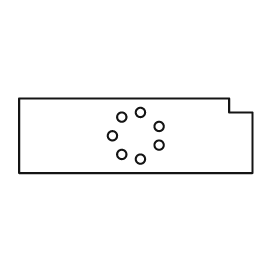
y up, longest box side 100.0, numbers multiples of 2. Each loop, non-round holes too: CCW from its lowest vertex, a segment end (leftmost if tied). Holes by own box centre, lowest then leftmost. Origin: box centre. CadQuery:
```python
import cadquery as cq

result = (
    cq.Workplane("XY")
    .moveTo(-50.0, -16.0)
    .lineTo(50.0, -16.0)
    .lineTo(50.0, 10.0)
    .lineTo(40.0, 10.0)
    .lineTo(40.0, 16.0)
    .lineTo(-50.0, 16.0)
    .close()
    .moveTo(2.0, -10.0)
    .circle(2.0)
    .moveTo(-6.0, -8.0)
    .circle(2.0)
    .moveTo(10.0, -4.0)
    .circle(2.0)
    .moveTo(-10.0, 0.0)
    .circle(2.0)
    .moveTo(10.0, 4.0)
    .circle(2.0)
    .moveTo(-6.0, 8.0)
    .circle(2.0)
    .moveTo(2.0, 10.0)
    .circle(2.0)
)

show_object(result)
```